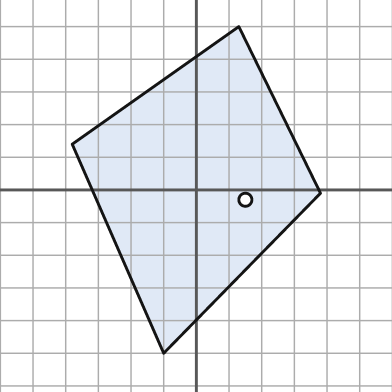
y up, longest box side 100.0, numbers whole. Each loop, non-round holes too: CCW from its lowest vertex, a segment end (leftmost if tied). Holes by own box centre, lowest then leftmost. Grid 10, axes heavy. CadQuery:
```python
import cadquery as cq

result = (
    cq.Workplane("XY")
    .moveTo(-10.0, -50.0)
    .lineTo(38.0, -1.0)
    .lineTo(13.0, 50.0)
    .lineTo(-38.0, 14.0)
    .close()
    .moveTo(15.0, -3.0)
    .circle(2.0)
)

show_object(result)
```